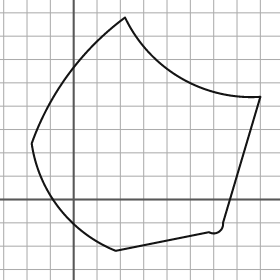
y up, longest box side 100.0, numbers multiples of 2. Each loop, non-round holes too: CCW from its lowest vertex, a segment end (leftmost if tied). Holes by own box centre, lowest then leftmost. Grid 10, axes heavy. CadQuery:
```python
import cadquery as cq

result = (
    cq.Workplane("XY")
    .moveTo(18.0, -22.0)
    .lineTo(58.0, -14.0)
    .threePointArc((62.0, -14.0), (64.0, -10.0))
    .lineTo(80.0, 44.0)
    .threePointArc((46.0, 52.0), (22.0, 78.0))
    .threePointArc((-2.0, 54.0), (-18.0, 24.0))
    .threePointArc((-6.0, -4.0), (18.0, -22.0))
    .close()
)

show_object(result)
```